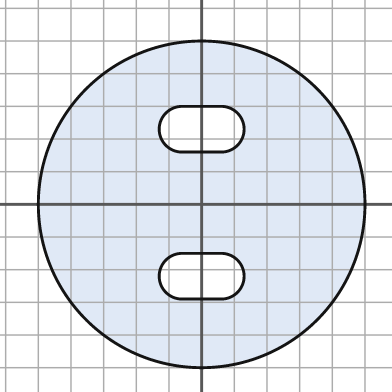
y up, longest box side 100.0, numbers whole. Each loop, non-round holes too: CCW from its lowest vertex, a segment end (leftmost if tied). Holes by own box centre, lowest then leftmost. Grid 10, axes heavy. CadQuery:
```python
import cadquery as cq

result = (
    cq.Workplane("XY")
    .moveTo(0.0, 0.0)
    .circle(50.0)
    .moveTo(-6.0, -29.0)
    .lineTo(6.0, -29.0)
    .threePointArc((13.0, -22.0), (6.0, -15.0))
    .lineTo(-6.0, -15.0)
    .threePointArc((-13.0, -22.0), (-6.0, -29.0))
    .close()
    .moveTo(-6.0, 16.0)
    .lineTo(6.0, 16.0)
    .threePointArc((13.0, 23.0), (6.0, 30.0))
    .lineTo(-6.0, 30.0)
    .threePointArc((-13.0, 23.0), (-6.0, 16.0))
    .close()
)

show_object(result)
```